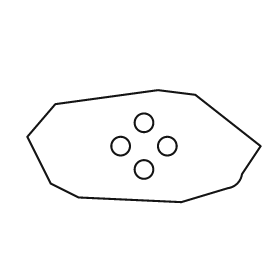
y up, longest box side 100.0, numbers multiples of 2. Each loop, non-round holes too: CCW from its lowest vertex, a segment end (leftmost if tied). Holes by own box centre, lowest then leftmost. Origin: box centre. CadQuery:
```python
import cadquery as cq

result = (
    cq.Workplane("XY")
    .moveTo(16.0, -24.0)
    .lineTo(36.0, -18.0)
    .threePointArc((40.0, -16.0), (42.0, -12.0))
    .lineTo(50.0, 0.0)
    .lineTo(22.0, 22.0)
    .lineTo(6.0, 24.0)
    .lineTo(-38.0, 18.0)
    .lineTo(-50.0, 4.0)
    .lineTo(-40.0, -16.0)
    .lineTo(-28.0, -22.0)
    .close()
    .moveTo(0.0, -10.0)
    .circle(4.0)
    .moveTo(-10.0, 0.0)
    .circle(4.0)
    .moveTo(10.0, 0.0)
    .circle(4.0)
    .moveTo(0.0, 10.0)
    .circle(4.0)
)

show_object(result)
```